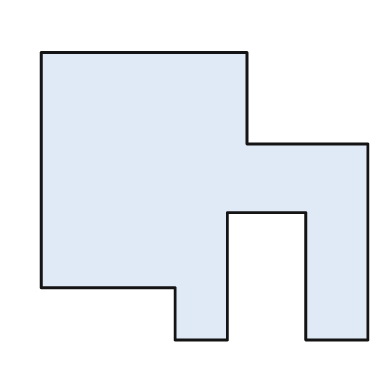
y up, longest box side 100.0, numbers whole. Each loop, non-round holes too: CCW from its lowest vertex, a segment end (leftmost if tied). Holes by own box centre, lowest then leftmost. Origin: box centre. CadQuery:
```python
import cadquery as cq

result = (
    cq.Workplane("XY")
    .moveTo(-9.0, -44.0)
    .lineTo(7.0, -44.0)
    .lineTo(7.0, -5.0)
    .lineTo(31.0, -5.0)
    .lineTo(31.0, -44.0)
    .lineTo(50.0, -44.0)
    .lineTo(50.0, 16.0)
    .lineTo(13.0, 16.0)
    .lineTo(13.0, 44.0)
    .lineTo(-50.0, 44.0)
    .lineTo(-50.0, -28.0)
    .lineTo(-9.0, -28.0)
    .close()
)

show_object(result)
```